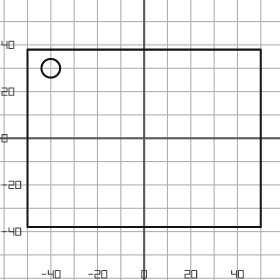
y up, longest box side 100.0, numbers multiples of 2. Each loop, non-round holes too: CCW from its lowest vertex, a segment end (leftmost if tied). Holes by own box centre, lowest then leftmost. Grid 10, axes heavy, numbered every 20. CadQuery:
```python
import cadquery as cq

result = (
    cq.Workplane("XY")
    .moveTo(-50.0, -38.0)
    .lineTo(50.0, -38.0)
    .lineTo(50.0, 38.0)
    .lineTo(-50.0, 38.0)
    .close()
    .moveTo(-40.0, 30.0)
    .circle(4.0)
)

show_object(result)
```